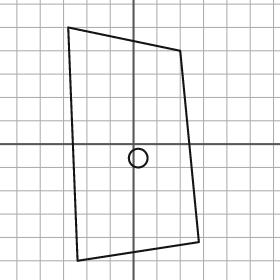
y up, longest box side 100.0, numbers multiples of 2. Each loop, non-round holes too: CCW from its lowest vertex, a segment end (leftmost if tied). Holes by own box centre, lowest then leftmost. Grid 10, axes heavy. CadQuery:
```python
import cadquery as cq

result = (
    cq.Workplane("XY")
    .moveTo(-24.0, -50.0)
    .lineTo(28.0, -42.0)
    .lineTo(20.0, 40.0)
    .lineTo(-28.0, 50.0)
    .close()
    .moveTo(2.0, -6.0)
    .circle(4.0)
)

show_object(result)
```